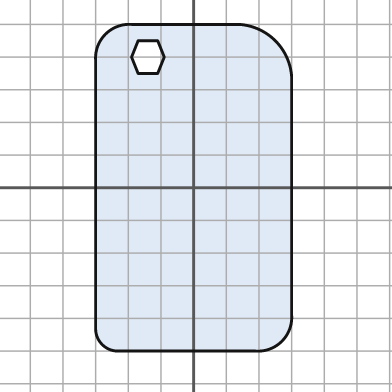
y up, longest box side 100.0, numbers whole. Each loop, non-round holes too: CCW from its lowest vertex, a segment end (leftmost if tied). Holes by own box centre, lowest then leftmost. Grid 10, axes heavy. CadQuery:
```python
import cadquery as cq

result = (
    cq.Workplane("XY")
    .moveTo(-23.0, -50.0)
    .lineTo(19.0, -50.0)
    .threePointArc((27.0, -47.0), (30.0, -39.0))
    .lineTo(30.0, 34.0)
    .threePointArc((25.0, 45.0), (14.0, 50.0))
    .lineTo(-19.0, 50.0)
    .threePointArc((-27.0, 47.0), (-30.0, 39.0))
    .lineTo(-30.0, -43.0)
    .threePointArc((-28.0, -48.0), (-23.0, -50.0))
    .close()
    .moveTo(-17.0, 35.0)
    .lineTo(-11.0, 35.0)
    .lineTo(-9.0, 40.0)
    .lineTo(-11.0, 45.0)
    .lineTo(-17.0, 45.0)
    .lineTo(-19.0, 40.0)
    .close()
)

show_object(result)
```